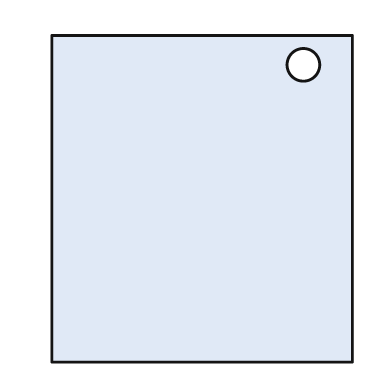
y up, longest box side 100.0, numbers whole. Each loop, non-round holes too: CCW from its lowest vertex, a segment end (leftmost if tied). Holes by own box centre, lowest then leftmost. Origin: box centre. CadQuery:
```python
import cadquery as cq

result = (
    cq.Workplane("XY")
    .moveTo(-46.0, -50.0)
    .lineTo(46.0, -50.0)
    .lineTo(46.0, 50.0)
    .lineTo(-46.0, 50.0)
    .close()
    .moveTo(31.0, 41.0)
    .circle(5.0)
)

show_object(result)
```